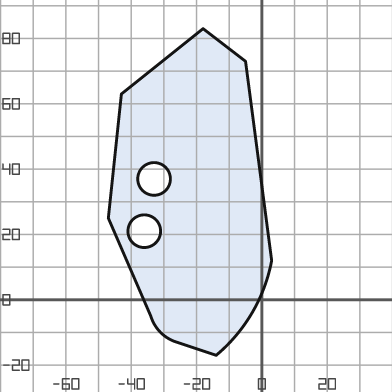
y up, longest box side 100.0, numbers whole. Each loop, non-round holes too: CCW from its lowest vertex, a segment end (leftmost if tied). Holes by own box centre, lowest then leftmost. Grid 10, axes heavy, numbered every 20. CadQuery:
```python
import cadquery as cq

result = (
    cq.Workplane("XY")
    .moveTo(-14.0, -17.0)
    .threePointArc((-3.0, -4.0), (3.0, 12.0))
    .lineTo(-5.0, 73.0)
    .lineTo(-18.0, 83.0)
    .lineTo(-43.0, 63.0)
    .lineTo(-47.0, 25.0)
    .lineTo(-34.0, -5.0)
    .threePointArc((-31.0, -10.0), (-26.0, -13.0))
    .close()
    .moveTo(-36.0, 21.0)
    .circle(5.0)
    .moveTo(-33.0, 37.0)
    .circle(5.0)
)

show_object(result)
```